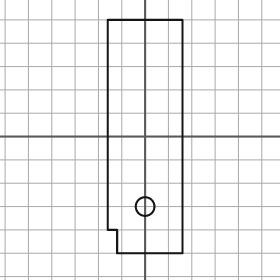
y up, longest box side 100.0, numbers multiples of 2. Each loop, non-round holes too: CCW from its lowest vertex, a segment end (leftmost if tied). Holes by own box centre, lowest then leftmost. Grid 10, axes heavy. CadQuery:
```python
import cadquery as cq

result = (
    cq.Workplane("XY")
    .moveTo(-12.0, -50.0)
    .lineTo(16.0, -50.0)
    .lineTo(16.0, 50.0)
    .lineTo(-16.0, 50.0)
    .lineTo(-16.0, -40.0)
    .lineTo(-12.0, -40.0)
    .close()
    .moveTo(0.0, -30.0)
    .circle(4.0)
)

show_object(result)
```